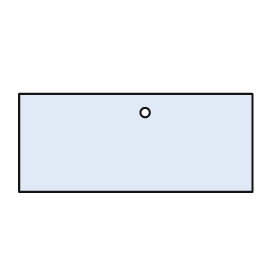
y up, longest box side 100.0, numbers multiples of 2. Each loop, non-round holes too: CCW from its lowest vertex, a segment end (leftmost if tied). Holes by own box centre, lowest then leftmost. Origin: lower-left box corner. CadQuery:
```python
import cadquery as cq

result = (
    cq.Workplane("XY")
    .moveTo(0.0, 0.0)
    .lineTo(100.0, 0.0)
    .lineTo(100.0, 42.0)
    .lineTo(0.0, 42.0)
    .close()
    .moveTo(54.0, 34.0)
    .circle(2.0)
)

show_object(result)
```